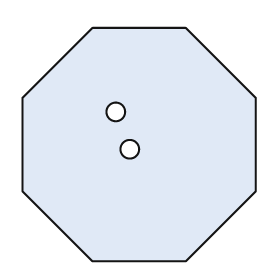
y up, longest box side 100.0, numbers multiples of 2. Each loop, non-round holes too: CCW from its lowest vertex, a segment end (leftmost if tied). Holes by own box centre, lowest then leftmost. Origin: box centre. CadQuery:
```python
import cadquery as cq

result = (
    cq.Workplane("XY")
    .moveTo(-20.0, -50.0)
    .lineTo(20.0, -50.0)
    .lineTo(50.0, -20.0)
    .lineTo(50.0, 20.0)
    .lineTo(20.0, 50.0)
    .lineTo(-20.0, 50.0)
    .lineTo(-50.0, 20.0)
    .lineTo(-50.0, -20.0)
    .close()
    .moveTo(-4.0, -2.0)
    .circle(4.0)
    .moveTo(-10.0, 14.0)
    .circle(4.0)
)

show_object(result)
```